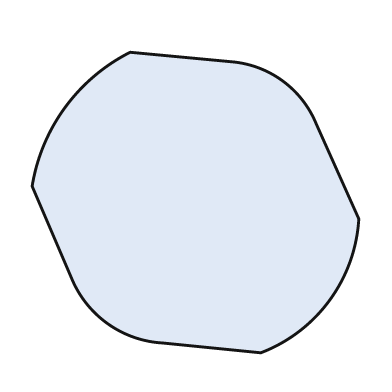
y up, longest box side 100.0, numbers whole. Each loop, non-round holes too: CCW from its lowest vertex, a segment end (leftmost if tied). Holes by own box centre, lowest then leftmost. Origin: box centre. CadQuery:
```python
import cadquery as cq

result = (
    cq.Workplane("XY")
    .moveTo(20.0, -46.0)
    .threePointArc((41.0, -30.0), (50.0, -5.0))
    .lineTo(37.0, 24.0)
    .threePointArc((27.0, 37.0), (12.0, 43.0))
    .lineTo(-20.0, 46.0)
    .threePointArc((-40.0, 29.0), (-50.0, 5.0))
    .lineTo(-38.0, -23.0)
    .threePointArc((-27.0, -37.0), (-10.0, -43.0))
    .close()
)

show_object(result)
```